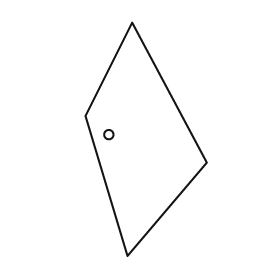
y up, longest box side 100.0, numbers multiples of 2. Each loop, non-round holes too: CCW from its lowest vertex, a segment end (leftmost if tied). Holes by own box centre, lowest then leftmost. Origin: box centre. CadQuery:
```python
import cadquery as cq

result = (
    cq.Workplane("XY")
    .moveTo(-8.0, -50.0)
    .lineTo(26.0, -10.0)
    .lineTo(-6.0, 50.0)
    .lineTo(-26.0, 10.0)
    .close()
    .moveTo(-16.0, 2.0)
    .circle(2.0)
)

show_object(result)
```